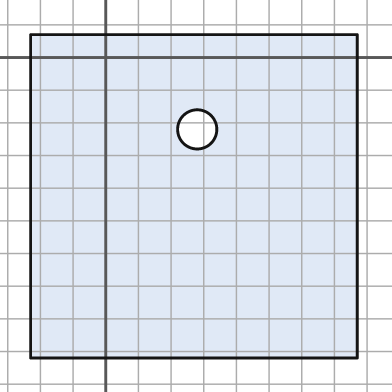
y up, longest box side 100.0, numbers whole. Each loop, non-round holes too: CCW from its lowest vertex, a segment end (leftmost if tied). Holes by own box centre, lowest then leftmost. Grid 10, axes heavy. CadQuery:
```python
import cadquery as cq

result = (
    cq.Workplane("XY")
    .moveTo(-23.0, -92.0)
    .lineTo(77.0, -92.0)
    .lineTo(77.0, 7.0)
    .lineTo(-23.0, 7.0)
    .close()
    .moveTo(28.0, -22.0)
    .circle(6.0)
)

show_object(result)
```